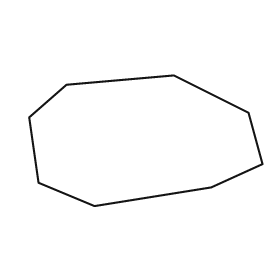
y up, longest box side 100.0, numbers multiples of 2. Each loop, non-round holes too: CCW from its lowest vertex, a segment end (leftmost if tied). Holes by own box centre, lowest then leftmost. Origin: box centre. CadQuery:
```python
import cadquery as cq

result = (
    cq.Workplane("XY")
    .moveTo(-22.0, -28.0)
    .lineTo(28.0, -20.0)
    .lineTo(50.0, -10.0)
    .lineTo(44.0, 12.0)
    .lineTo(12.0, 28.0)
    .lineTo(-34.0, 24.0)
    .lineTo(-50.0, 10.0)
    .lineTo(-46.0, -18.0)
    .close()
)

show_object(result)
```